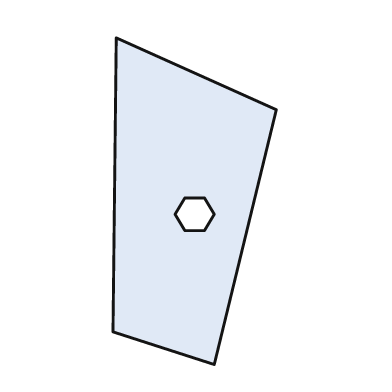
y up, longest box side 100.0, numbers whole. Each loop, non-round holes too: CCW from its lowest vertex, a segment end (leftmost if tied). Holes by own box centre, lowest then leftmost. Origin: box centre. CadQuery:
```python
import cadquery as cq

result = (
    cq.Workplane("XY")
    .moveTo(6.0, -50.0)
    .lineTo(25.0, 28.0)
    .lineTo(-24.0, 50.0)
    .lineTo(-25.0, -40.0)
    .close()
    .moveTo(-3.0, -9.0)
    .lineTo(3.0, -9.0)
    .lineTo(6.0, -4.0)
    .lineTo(3.0, 1.0)
    .lineTo(-3.0, 1.0)
    .lineTo(-6.0, -4.0)
    .close()
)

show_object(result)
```